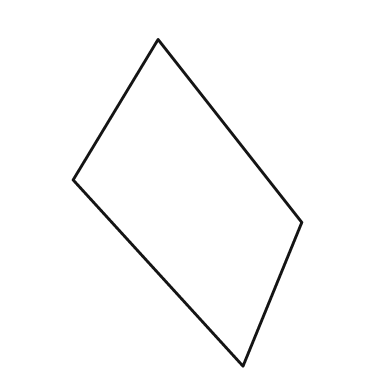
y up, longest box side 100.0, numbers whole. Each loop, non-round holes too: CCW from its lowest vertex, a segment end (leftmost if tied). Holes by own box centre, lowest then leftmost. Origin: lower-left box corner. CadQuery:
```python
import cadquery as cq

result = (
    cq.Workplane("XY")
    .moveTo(52.0, 0.0)
    .lineTo(70.0, 44.0)
    .lineTo(26.0, 100.0)
    .lineTo(0.0, 57.0)
    .close()
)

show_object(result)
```